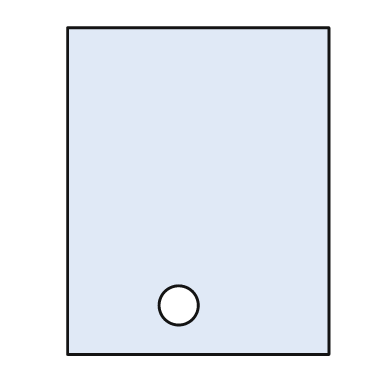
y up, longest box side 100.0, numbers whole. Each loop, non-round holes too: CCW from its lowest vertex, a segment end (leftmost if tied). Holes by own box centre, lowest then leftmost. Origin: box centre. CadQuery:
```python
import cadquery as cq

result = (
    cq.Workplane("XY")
    .moveTo(-40.0, -50.0)
    .lineTo(40.0, -50.0)
    .lineTo(40.0, 50.0)
    .lineTo(-40.0, 50.0)
    .close()
    .moveTo(-6.0, -35.0)
    .circle(6.0)
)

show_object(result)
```